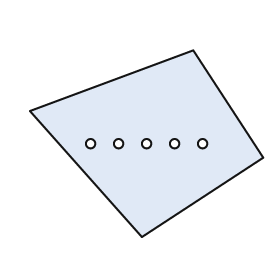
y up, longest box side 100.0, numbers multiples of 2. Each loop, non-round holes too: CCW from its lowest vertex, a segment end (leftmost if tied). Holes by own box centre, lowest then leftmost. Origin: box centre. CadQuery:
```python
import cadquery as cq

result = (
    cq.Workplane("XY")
    .moveTo(-2.0, -40.0)
    .lineTo(50.0, -6.0)
    .lineTo(20.0, 40.0)
    .lineTo(-50.0, 14.0)
    .close()
    .moveTo(-24.0, 0.0)
    .circle(2.0)
    .moveTo(-12.0, 0.0)
    .circle(2.0)
    .moveTo(0.0, 0.0)
    .circle(2.0)
    .moveTo(12.0, 0.0)
    .circle(2.0)
    .moveTo(24.0, 0.0)
    .circle(2.0)
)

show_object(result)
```